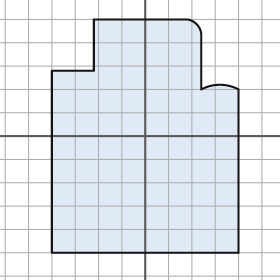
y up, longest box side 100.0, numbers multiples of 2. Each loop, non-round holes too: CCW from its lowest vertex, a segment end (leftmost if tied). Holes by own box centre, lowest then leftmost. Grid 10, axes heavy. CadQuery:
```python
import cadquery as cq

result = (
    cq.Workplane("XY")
    .moveTo(-40.0, -50.0)
    .lineTo(40.0, -50.0)
    .lineTo(40.0, 20.0)
    .threePointArc((32.0, 22.0), (24.0, 20.0))
    .lineTo(24.0, 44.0)
    .threePointArc((22.0, 48.0), (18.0, 50.0))
    .lineTo(-22.0, 50.0)
    .lineTo(-22.0, 28.0)
    .lineTo(-40.0, 28.0)
    .close()
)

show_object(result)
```